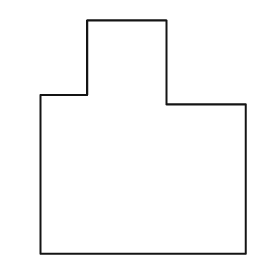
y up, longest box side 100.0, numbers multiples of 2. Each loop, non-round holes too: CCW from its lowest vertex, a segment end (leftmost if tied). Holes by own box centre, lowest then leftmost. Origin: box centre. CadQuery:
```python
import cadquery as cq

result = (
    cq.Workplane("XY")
    .moveTo(-44.0, -50.0)
    .lineTo(44.0, -50.0)
    .lineTo(44.0, 14.0)
    .lineTo(10.0, 14.0)
    .lineTo(10.0, 50.0)
    .lineTo(-24.0, 50.0)
    .lineTo(-24.0, 18.0)
    .lineTo(-44.0, 18.0)
    .close()
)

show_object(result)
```